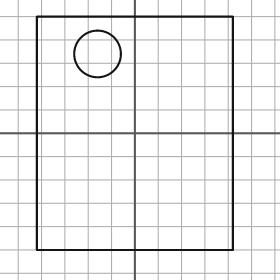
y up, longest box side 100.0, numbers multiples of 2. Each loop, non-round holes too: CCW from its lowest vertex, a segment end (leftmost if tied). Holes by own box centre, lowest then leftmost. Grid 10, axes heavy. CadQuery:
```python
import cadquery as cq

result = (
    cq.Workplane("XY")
    .moveTo(-42.0, -50.0)
    .lineTo(42.0, -50.0)
    .lineTo(42.0, 50.0)
    .lineTo(-42.0, 50.0)
    .close()
    .moveTo(-16.0, 34.0)
    .circle(10.0)
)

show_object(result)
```